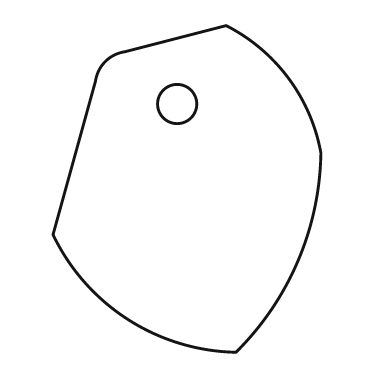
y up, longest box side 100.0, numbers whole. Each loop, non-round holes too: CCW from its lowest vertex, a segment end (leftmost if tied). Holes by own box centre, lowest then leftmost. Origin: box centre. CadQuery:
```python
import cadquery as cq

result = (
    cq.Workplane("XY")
    .moveTo(15.0, -50.0)
    .threePointArc((34.0, -22.0), (41.0, 11.0))
    .threePointArc((31.0, 34.0), (12.0, 50.0))
    .lineTo(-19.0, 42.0)
    .threePointArc((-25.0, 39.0), (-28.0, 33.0))
    .lineTo(-41.0, -14.0)
    .threePointArc((-18.0, -40.0), (15.0, -50.0))
    .close()
    .moveTo(-3.0, 26.0)
    .circle(6.0)
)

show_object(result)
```